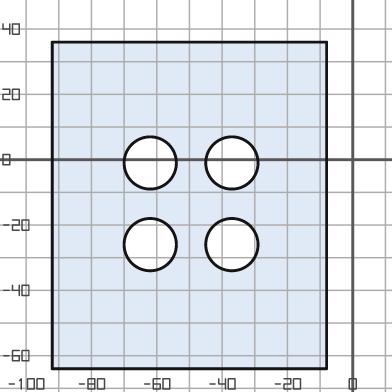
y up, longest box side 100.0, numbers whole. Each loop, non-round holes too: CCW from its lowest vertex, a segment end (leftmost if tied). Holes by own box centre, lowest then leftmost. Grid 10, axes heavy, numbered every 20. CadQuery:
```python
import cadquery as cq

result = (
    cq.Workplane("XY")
    .moveTo(-92.0, -64.0)
    .lineTo(-8.0, -64.0)
    .lineTo(-8.0, 36.0)
    .lineTo(-92.0, 36.0)
    .close()
    .moveTo(-62.0, -26.0)
    .circle(8.0)
    .moveTo(-37.0, -26.0)
    .circle(8.0)
    .moveTo(-62.0, -1.0)
    .circle(8.0)
    .moveTo(-37.0, -1.0)
    .circle(8.0)
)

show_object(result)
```